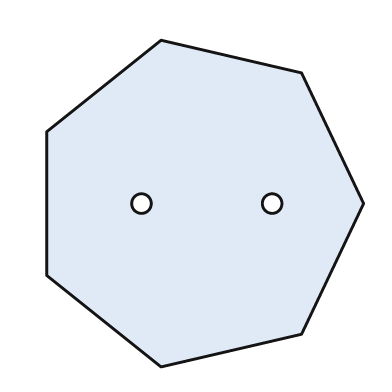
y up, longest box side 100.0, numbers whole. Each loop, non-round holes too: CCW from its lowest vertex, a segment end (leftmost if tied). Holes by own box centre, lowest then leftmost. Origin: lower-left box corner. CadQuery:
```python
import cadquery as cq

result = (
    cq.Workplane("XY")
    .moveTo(35.0, 0.0)
    .lineTo(78.0, 10.0)
    .lineTo(97.0, 50.0)
    .lineTo(78.0, 90.0)
    .lineTo(35.0, 100.0)
    .lineTo(0.0, 72.0)
    .lineTo(0.0, 28.0)
    .close()
    .moveTo(29.0, 50.0)
    .circle(3.0)
    .moveTo(69.0, 50.0)
    .circle(3.0)
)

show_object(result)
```